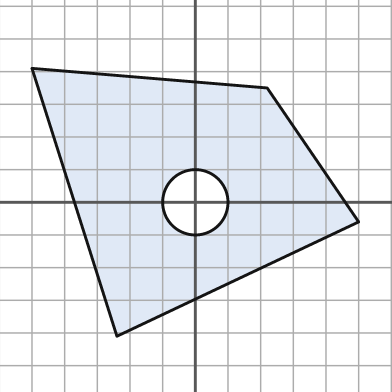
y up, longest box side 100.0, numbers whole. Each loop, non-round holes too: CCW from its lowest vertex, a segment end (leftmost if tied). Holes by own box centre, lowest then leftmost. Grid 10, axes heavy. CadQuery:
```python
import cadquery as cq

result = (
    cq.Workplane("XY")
    .moveTo(-24.0, -41.0)
    .lineTo(50.0, -6.0)
    .lineTo(22.0, 35.0)
    .lineTo(-50.0, 41.0)
    .close()
    .moveTo(0.0, 0.0)
    .circle(10.0)
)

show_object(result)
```